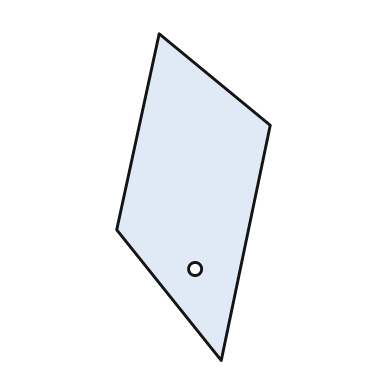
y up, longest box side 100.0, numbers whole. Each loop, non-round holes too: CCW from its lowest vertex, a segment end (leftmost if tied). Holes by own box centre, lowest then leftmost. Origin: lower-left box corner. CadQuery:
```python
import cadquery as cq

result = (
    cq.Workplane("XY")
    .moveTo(32.0, 0.0)
    .lineTo(47.0, 72.0)
    .lineTo(13.0, 100.0)
    .lineTo(0.0, 40.0)
    .close()
    .moveTo(24.0, 28.0)
    .circle(2.0)
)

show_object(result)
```